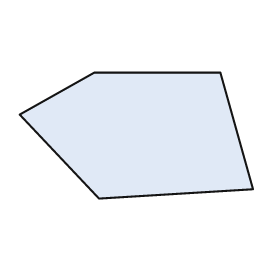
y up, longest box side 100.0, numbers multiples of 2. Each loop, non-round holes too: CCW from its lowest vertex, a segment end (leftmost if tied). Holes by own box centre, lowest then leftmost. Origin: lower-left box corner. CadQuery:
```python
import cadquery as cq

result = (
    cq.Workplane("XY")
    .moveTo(34.0, 0.0)
    .lineTo(100.0, 4.0)
    .lineTo(86.0, 54.0)
    .lineTo(32.0, 54.0)
    .lineTo(0.0, 36.0)
    .close()
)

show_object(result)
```